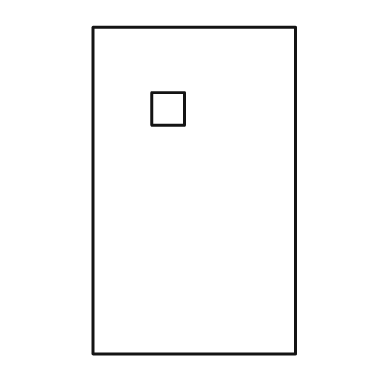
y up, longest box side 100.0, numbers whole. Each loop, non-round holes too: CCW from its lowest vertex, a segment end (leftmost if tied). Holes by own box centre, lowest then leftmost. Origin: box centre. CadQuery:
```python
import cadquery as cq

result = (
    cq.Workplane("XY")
    .moveTo(-31.0, -50.0)
    .lineTo(31.0, -50.0)
    .lineTo(31.0, 50.0)
    .lineTo(-31.0, 50.0)
    .close()
    .moveTo(-13.0, 20.0)
    .lineTo(-3.0, 20.0)
    .lineTo(-3.0, 30.0)
    .lineTo(-13.0, 30.0)
    .close()
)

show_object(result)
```